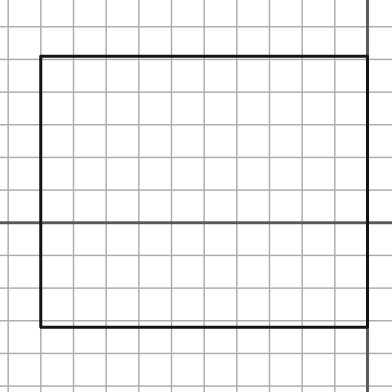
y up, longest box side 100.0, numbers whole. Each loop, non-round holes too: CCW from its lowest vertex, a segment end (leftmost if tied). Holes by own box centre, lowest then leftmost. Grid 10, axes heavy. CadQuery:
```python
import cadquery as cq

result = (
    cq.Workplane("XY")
    .moveTo(-100.0, -32.0)
    .lineTo(0.0, -32.0)
    .lineTo(0.0, 51.0)
    .lineTo(-100.0, 51.0)
    .close()
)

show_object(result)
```